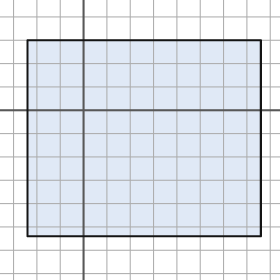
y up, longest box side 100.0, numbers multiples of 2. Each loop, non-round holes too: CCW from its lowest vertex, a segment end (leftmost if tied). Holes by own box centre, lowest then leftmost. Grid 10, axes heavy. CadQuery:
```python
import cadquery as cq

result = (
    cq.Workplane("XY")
    .moveTo(-24.0, -54.0)
    .lineTo(76.0, -54.0)
    .lineTo(76.0, 30.0)
    .lineTo(-24.0, 30.0)
    .close()
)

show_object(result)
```